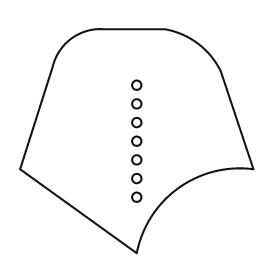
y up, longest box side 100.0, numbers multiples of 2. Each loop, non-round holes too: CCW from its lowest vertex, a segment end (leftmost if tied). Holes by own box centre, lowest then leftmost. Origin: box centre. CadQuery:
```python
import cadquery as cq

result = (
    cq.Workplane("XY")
    .moveTo(0.0, -48.0)
    .threePointArc((18.0, -20.0), (50.0, -12.0))
    .lineTo(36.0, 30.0)
    .threePointArc((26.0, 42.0), (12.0, 48.0))
    .lineTo(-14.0, 48.0)
    .threePointArc((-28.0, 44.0), (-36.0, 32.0))
    .lineTo(-50.0, -12.0)
    .close()
    .moveTo(0.0, -24.0)
    .circle(2.0)
    .moveTo(0.0, -16.0)
    .circle(2.0)
    .moveTo(0.0, -8.0)
    .circle(2.0)
    .moveTo(0.0, 0.0)
    .circle(2.0)
    .moveTo(0.0, 8.0)
    .circle(2.0)
    .moveTo(0.0, 16.0)
    .circle(2.0)
    .moveTo(0.0, 24.0)
    .circle(2.0)
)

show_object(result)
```